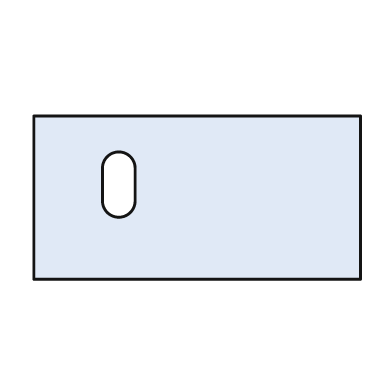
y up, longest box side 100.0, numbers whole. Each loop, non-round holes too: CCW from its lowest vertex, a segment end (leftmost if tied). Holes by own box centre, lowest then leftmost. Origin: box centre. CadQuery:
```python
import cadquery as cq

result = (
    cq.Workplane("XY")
    .moveTo(-50.0, -25.0)
    .lineTo(50.0, -25.0)
    .lineTo(50.0, 25.0)
    .lineTo(-50.0, 25.0)
    .close()
    .moveTo(-29.0, -1.0)
    .threePointArc((-24.0, -6.0), (-19.0, -1.0))
    .lineTo(-19.0, 9.0)
    .threePointArc((-24.0, 14.0), (-29.0, 9.0))
    .close()
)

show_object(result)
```